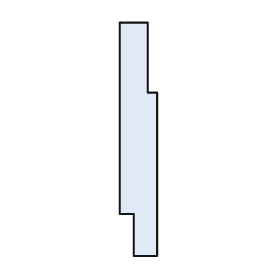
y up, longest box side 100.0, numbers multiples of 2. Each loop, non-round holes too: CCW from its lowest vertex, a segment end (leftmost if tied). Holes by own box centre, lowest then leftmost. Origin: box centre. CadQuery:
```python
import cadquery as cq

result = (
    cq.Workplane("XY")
    .moveTo(-2.0, -50.0)
    .lineTo(8.0, -50.0)
    .lineTo(8.0, 20.0)
    .lineTo(4.0, 20.0)
    .lineTo(4.0, 50.0)
    .lineTo(-8.0, 50.0)
    .lineTo(-8.0, -32.0)
    .lineTo(-2.0, -32.0)
    .close()
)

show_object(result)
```